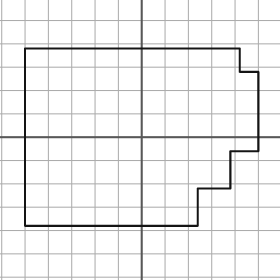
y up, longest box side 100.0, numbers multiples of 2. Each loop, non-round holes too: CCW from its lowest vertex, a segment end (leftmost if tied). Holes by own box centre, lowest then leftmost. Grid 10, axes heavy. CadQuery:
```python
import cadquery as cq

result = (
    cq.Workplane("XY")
    .moveTo(-50.0, -38.0)
    .lineTo(24.0, -38.0)
    .lineTo(24.0, -22.0)
    .lineTo(38.0, -22.0)
    .lineTo(38.0, -6.0)
    .lineTo(50.0, -6.0)
    .lineTo(50.0, 28.0)
    .lineTo(42.0, 28.0)
    .lineTo(42.0, 38.0)
    .lineTo(-50.0, 38.0)
    .close()
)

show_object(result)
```